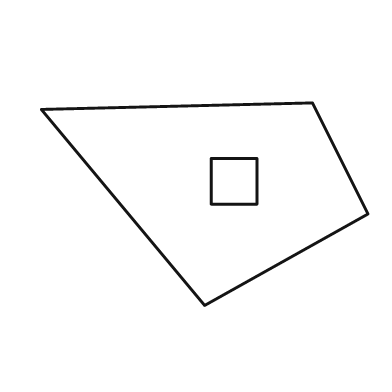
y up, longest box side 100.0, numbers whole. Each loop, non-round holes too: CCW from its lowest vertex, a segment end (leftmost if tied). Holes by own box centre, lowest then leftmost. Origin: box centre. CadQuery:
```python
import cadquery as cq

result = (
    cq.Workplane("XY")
    .moveTo(0.0, -31.0)
    .lineTo(50.0, -3.0)
    .lineTo(33.0, 31.0)
    .lineTo(-50.0, 29.0)
    .close()
    .moveTo(2.0, 0.0)
    .lineTo(16.0, 0.0)
    .lineTo(16.0, 14.0)
    .lineTo(2.0, 14.0)
    .close()
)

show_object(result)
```